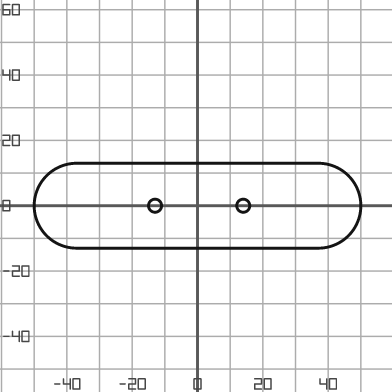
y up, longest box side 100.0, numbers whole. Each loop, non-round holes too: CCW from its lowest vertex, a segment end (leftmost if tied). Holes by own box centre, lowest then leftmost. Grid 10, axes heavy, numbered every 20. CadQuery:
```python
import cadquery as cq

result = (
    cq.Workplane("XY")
    .moveTo(-37.0, -13.0)
    .lineTo(37.0, -13.0)
    .threePointArc((50.0, 0.0), (37.0, 13.0))
    .lineTo(-37.0, 13.0)
    .threePointArc((-50.0, 0.0), (-37.0, -13.0))
    .close()
    .moveTo(-13.0, 0.0)
    .circle(2.0)
    .moveTo(14.0, 0.0)
    .circle(2.0)
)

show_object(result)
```